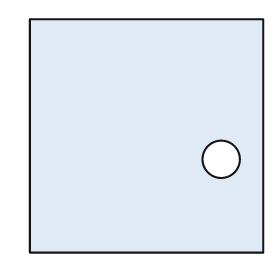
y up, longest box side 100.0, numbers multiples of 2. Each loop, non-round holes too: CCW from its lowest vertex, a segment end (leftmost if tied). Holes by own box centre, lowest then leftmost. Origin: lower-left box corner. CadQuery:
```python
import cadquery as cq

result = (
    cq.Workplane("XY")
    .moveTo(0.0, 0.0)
    .lineTo(100.0, 0.0)
    .lineTo(100.0, 100.0)
    .lineTo(0.0, 100.0)
    .close()
    .moveTo(82.0, 40.0)
    .circle(8.0)
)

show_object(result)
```